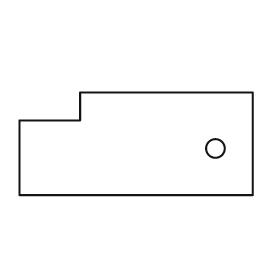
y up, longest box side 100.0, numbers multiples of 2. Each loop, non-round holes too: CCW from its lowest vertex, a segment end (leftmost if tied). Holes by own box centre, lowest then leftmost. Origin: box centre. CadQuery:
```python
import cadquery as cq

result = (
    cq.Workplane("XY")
    .moveTo(-50.0, -22.0)
    .lineTo(50.0, -22.0)
    .lineTo(50.0, 22.0)
    .lineTo(-24.0, 22.0)
    .lineTo(-24.0, 10.0)
    .lineTo(-50.0, 10.0)
    .close()
    .moveTo(34.0, -2.0)
    .circle(4.0)
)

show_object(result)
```